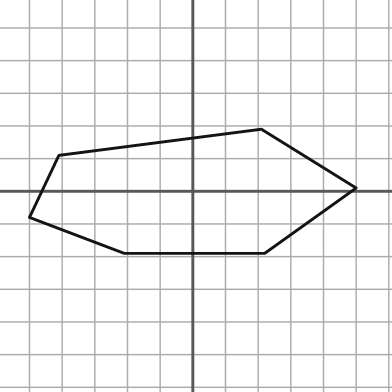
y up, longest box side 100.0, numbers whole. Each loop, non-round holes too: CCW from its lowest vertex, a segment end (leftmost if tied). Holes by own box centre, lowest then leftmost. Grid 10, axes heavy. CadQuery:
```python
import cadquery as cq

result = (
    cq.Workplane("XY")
    .moveTo(-21.0, -19.0)
    .lineTo(22.0, -19.0)
    .lineTo(50.0, 1.0)
    .lineTo(21.0, 19.0)
    .lineTo(-41.0, 11.0)
    .lineTo(-50.0, -8.0)
    .close()
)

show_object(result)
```